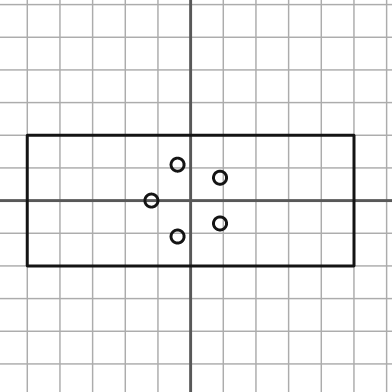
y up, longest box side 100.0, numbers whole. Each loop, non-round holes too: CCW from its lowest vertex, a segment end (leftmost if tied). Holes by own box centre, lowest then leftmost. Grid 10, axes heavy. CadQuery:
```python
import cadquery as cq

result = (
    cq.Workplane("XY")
    .moveTo(-50.0, -20.0)
    .lineTo(50.0, -20.0)
    .lineTo(50.0, 20.0)
    .lineTo(-50.0, 20.0)
    .close()
    .moveTo(-4.0, -11.0)
    .circle(2.0)
    .moveTo(9.0, -7.0)
    .circle(2.0)
    .moveTo(-12.0, 0.0)
    .circle(2.0)
    .moveTo(9.0, 7.0)
    .circle(2.0)
    .moveTo(-4.0, 11.0)
    .circle(2.0)
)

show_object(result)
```